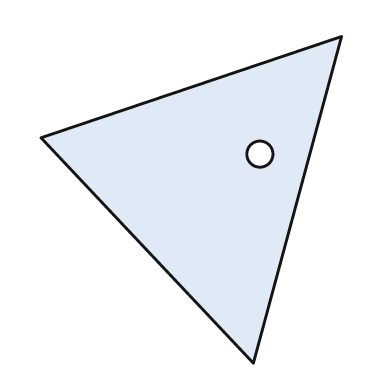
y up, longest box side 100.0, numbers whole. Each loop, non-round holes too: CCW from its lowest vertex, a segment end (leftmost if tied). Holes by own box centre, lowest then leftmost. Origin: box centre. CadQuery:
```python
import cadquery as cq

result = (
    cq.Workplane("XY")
    .moveTo(19.0, -50.0)
    .lineTo(46.0, 50.0)
    .lineTo(-46.0, 19.0)
    .close()
    .moveTo(21.0, 14.0)
    .circle(4.0)
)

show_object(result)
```